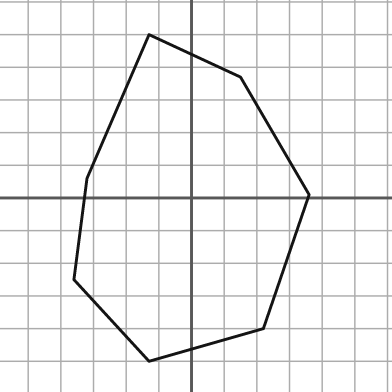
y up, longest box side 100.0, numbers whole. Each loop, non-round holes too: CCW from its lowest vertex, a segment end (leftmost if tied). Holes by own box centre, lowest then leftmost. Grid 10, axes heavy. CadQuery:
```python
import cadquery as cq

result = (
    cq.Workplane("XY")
    .moveTo(-13.0, -50.0)
    .lineTo(22.0, -40.0)
    .lineTo(36.0, 1.0)
    .lineTo(15.0, 37.0)
    .lineTo(-13.0, 50.0)
    .lineTo(-32.0, 6.0)
    .lineTo(-36.0, -25.0)
    .close()
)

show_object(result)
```